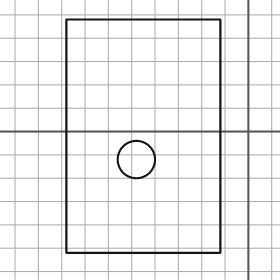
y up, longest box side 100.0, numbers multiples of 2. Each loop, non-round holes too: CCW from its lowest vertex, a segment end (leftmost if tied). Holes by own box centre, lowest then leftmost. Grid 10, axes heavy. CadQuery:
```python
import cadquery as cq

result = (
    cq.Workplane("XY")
    .moveTo(-78.0, -52.0)
    .lineTo(-12.0, -52.0)
    .lineTo(-12.0, 48.0)
    .lineTo(-78.0, 48.0)
    .close()
    .moveTo(-48.0, -12.0)
    .circle(8.0)
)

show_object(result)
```